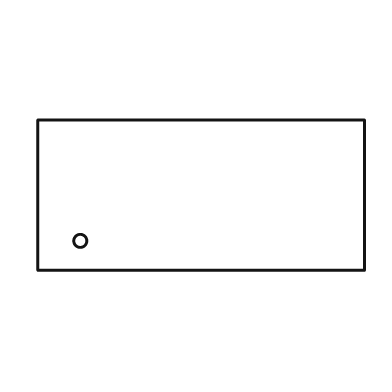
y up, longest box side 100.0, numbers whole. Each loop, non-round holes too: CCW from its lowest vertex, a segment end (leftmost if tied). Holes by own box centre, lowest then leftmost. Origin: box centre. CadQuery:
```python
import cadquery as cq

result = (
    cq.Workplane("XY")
    .moveTo(-50.0, -23.0)
    .lineTo(50.0, -23.0)
    .lineTo(50.0, 23.0)
    .lineTo(-50.0, 23.0)
    .close()
    .moveTo(-37.0, -14.0)
    .circle(2.0)
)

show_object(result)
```